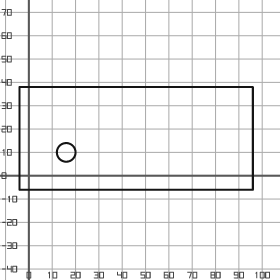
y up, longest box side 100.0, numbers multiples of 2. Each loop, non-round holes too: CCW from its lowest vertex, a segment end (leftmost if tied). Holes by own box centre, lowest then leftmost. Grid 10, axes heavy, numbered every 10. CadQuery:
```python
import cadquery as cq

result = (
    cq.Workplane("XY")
    .moveTo(-4.0, -6.0)
    .lineTo(96.0, -6.0)
    .lineTo(96.0, 38.0)
    .lineTo(-4.0, 38.0)
    .close()
    .moveTo(16.0, 10.0)
    .circle(4.0)
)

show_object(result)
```